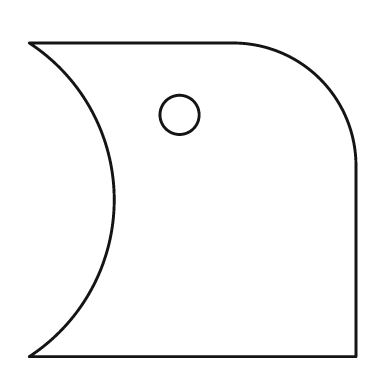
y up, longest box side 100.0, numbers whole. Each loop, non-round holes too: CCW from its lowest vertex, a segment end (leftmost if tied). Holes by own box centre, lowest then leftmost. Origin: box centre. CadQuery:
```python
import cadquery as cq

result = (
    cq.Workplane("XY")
    .moveTo(-50.0, -48.0)
    .lineTo(50.0, -48.0)
    .lineTo(50.0, 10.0)
    .threePointArc((39.0, 37.0), (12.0, 48.0))
    .lineTo(-50.0, 48.0)
    .threePointArc((-24.0, 0.0), (-50.0, -48.0))
    .close()
    .moveTo(-4.0, 26.0)
    .circle(6.0)
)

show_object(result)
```